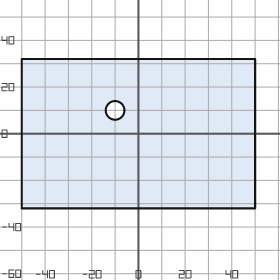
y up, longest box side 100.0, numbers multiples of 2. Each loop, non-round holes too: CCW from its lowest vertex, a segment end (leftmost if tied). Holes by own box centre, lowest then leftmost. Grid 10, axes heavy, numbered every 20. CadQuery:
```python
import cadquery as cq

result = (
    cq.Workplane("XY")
    .moveTo(-50.0, -32.0)
    .lineTo(50.0, -32.0)
    .lineTo(50.0, 32.0)
    .lineTo(-50.0, 32.0)
    .close()
    .moveTo(-10.0, 10.0)
    .circle(4.0)
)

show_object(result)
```